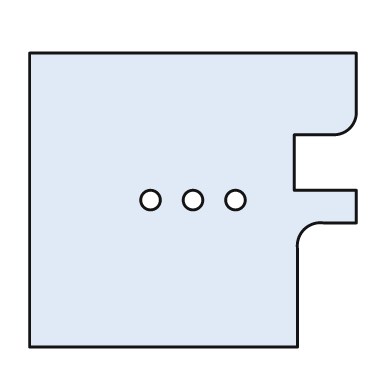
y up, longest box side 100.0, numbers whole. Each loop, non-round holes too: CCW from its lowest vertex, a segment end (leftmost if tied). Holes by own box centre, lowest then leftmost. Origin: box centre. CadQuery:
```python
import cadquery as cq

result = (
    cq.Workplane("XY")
    .moveTo(-50.0, -45.0)
    .lineTo(32.0, -45.0)
    .lineTo(32.0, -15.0)
    .threePointArc((34.0, -9.0), (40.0, -7.0))
    .lineTo(50.0, -7.0)
    .lineTo(50.0, 3.0)
    .lineTo(31.0, 3.0)
    .lineTo(31.0, 20.0)
    .lineTo(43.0, 20.0)
    .threePointArc((48.0, 22.0), (50.0, 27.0))
    .lineTo(50.0, 45.0)
    .lineTo(-50.0, 45.0)
    .close()
    .moveTo(-13.0, 0.0)
    .circle(3.0)
    .moveTo(0.0, 0.0)
    .circle(3.0)
    .moveTo(13.0, 0.0)
    .circle(3.0)
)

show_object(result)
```